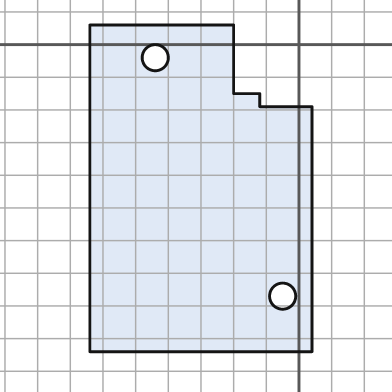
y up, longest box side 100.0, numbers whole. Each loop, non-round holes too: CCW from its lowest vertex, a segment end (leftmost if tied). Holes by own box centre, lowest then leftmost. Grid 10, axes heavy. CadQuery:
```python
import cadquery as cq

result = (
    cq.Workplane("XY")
    .moveTo(-64.0, -94.0)
    .lineTo(4.0, -94.0)
    .lineTo(4.0, -19.0)
    .lineTo(-12.0, -19.0)
    .lineTo(-12.0, -15.0)
    .lineTo(-20.0, -15.0)
    .lineTo(-20.0, 6.0)
    .lineTo(-64.0, 6.0)
    .close()
    .moveTo(-5.0, -77.0)
    .circle(4.0)
    .moveTo(-44.0, -4.0)
    .circle(4.0)
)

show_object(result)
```